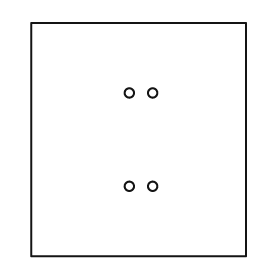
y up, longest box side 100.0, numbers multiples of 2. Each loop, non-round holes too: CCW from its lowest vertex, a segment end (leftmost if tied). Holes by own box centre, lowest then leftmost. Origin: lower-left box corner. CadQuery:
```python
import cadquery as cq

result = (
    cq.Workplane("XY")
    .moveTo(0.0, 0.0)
    .lineTo(92.0, 0.0)
    .lineTo(92.0, 100.0)
    .lineTo(0.0, 100.0)
    .close()
    .moveTo(42.0, 30.0)
    .circle(2.0)
    .moveTo(52.0, 30.0)
    .circle(2.0)
    .moveTo(42.0, 70.0)
    .circle(2.0)
    .moveTo(52.0, 70.0)
    .circle(2.0)
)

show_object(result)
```